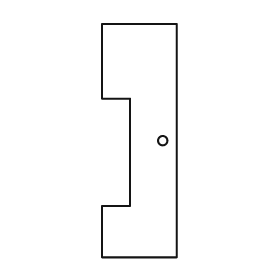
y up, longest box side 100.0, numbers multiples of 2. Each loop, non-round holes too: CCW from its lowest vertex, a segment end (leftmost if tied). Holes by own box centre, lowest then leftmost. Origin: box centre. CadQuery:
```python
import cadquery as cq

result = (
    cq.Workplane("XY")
    .moveTo(-16.0, -50.0)
    .lineTo(16.0, -50.0)
    .lineTo(16.0, 50.0)
    .lineTo(-16.0, 50.0)
    .lineTo(-16.0, 18.0)
    .lineTo(-4.0, 18.0)
    .lineTo(-4.0, -28.0)
    .lineTo(-16.0, -28.0)
    .close()
    .moveTo(10.0, 0.0)
    .circle(2.0)
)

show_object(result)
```